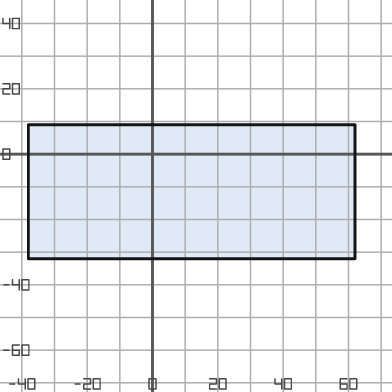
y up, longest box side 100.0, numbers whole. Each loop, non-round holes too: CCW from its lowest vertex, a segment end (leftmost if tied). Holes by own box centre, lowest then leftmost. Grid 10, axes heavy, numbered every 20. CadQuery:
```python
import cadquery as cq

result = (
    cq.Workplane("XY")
    .moveTo(-38.0, -32.0)
    .lineTo(62.0, -32.0)
    .lineTo(62.0, 9.0)
    .lineTo(-38.0, 9.0)
    .close()
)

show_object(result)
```